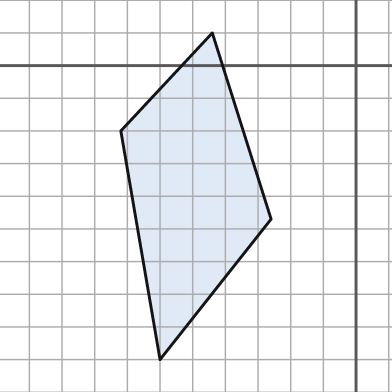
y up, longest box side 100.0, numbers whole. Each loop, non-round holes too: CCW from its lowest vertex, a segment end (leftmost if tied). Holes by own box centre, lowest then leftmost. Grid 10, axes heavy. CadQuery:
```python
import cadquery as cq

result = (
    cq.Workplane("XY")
    .moveTo(-60.0, -90.0)
    .lineTo(-26.0, -47.0)
    .lineTo(-44.0, 10.0)
    .lineTo(-72.0, -20.0)
    .close()
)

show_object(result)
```